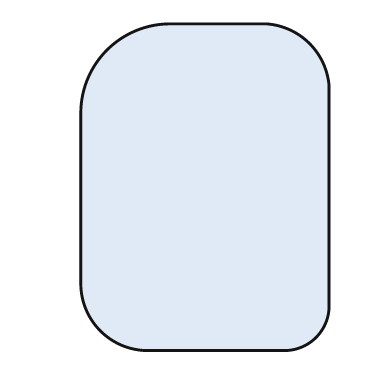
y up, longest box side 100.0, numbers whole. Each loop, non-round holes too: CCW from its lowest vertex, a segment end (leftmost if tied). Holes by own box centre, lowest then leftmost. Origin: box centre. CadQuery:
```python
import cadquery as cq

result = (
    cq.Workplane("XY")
    .moveTo(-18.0, -50.0)
    .lineTo(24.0, -50.0)
    .threePointArc((34.0, -46.0), (38.0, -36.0))
    .lineTo(38.0, 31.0)
    .threePointArc((32.0, 44.0), (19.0, 50.0))
    .lineTo(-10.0, 50.0)
    .threePointArc((-30.0, 42.0), (-38.0, 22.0))
    .lineTo(-38.0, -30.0)
    .threePointArc((-32.0, -44.0), (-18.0, -50.0))
    .close()
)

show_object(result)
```